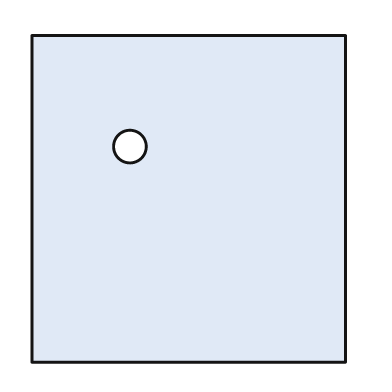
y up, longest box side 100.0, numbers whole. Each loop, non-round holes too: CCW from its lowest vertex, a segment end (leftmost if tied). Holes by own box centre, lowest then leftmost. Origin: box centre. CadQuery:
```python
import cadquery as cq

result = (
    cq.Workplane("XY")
    .moveTo(-48.0, -50.0)
    .lineTo(48.0, -50.0)
    .lineTo(48.0, 50.0)
    .lineTo(-48.0, 50.0)
    .close()
    .moveTo(-18.0, 16.0)
    .circle(5.0)
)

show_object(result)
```